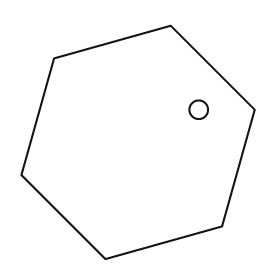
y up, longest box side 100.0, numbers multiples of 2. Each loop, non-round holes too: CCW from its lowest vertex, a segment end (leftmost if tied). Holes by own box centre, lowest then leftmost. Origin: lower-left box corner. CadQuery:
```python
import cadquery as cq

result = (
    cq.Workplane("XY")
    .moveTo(36.0, 0.0)
    .lineTo(86.0, 14.0)
    .lineTo(100.0, 64.0)
    .lineTo(64.0, 100.0)
    .lineTo(14.0, 86.0)
    .lineTo(0.0, 36.0)
    .close()
    .moveTo(76.0, 64.0)
    .circle(4.0)
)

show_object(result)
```